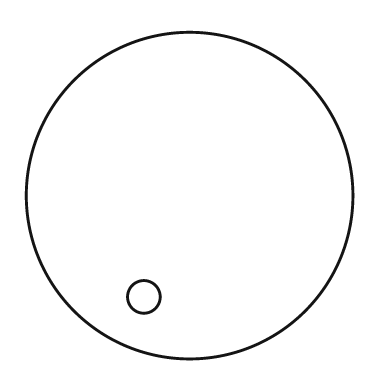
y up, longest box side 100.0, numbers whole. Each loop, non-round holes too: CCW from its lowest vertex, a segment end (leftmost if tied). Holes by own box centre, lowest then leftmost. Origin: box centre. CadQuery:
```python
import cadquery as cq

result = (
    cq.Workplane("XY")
    .moveTo(0.0, 0.0)
    .circle(50.0)
    .moveTo(-14.0, -31.0)
    .circle(5.0)
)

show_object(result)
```